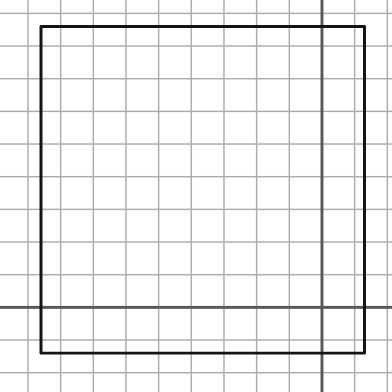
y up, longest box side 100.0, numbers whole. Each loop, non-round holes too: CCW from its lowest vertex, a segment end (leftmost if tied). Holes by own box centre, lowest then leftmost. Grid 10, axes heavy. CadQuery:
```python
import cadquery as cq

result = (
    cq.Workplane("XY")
    .moveTo(-86.0, -14.0)
    .lineTo(13.0, -14.0)
    .lineTo(13.0, 86.0)
    .lineTo(-86.0, 86.0)
    .close()
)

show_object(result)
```